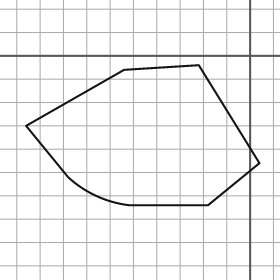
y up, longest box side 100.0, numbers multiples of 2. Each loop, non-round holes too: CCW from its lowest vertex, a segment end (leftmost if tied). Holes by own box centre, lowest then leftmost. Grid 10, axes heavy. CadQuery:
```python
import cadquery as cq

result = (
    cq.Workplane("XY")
    .moveTo(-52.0, -64.0)
    .lineTo(-18.0, -64.0)
    .lineTo(4.0, -46.0)
    .lineTo(-22.0, -4.0)
    .lineTo(-54.0, -6.0)
    .lineTo(-96.0, -30.0)
    .lineTo(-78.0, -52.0)
    .threePointArc((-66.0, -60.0), (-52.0, -64.0))
    .close()
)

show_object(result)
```